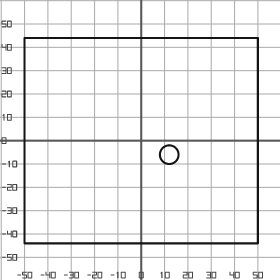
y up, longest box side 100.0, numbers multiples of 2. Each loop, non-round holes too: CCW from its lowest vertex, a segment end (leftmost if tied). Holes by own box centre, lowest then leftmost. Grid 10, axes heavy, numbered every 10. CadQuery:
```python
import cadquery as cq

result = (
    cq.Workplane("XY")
    .moveTo(-50.0, -44.0)
    .lineTo(50.0, -44.0)
    .lineTo(50.0, 44.0)
    .lineTo(-50.0, 44.0)
    .close()
    .moveTo(12.0, -6.0)
    .circle(4.0)
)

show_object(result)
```